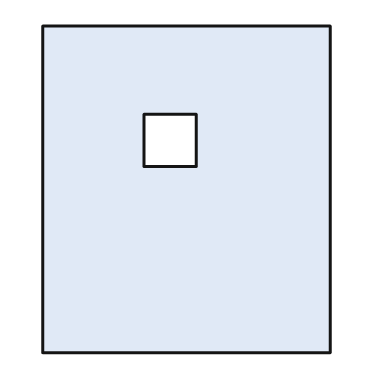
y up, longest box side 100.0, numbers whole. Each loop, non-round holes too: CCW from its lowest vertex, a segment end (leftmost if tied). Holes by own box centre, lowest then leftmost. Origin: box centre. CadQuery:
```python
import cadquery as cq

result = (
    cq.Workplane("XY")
    .moveTo(-44.0, -50.0)
    .lineTo(44.0, -50.0)
    .lineTo(44.0, 50.0)
    .lineTo(-44.0, 50.0)
    .close()
    .moveTo(-13.0, 7.0)
    .lineTo(3.0, 7.0)
    .lineTo(3.0, 23.0)
    .lineTo(-13.0, 23.0)
    .close()
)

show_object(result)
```